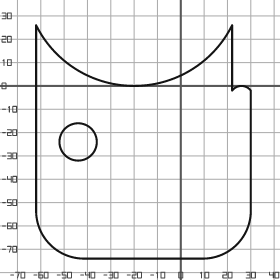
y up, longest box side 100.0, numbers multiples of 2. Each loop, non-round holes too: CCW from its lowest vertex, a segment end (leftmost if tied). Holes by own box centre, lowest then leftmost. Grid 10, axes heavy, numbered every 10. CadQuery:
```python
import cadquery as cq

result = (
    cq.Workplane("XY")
    .moveTo(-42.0, -74.0)
    .lineTo(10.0, -74.0)
    .threePointArc((24.0, -68.0), (30.0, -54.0))
    .lineTo(30.0, -2.0)
    .threePointArc((26.0, 0.0), (22.0, -2.0))
    .lineTo(22.0, 26.0)
    .threePointArc((-20.0, 0.0), (-62.0, 26.0))
    .lineTo(-62.0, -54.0)
    .threePointArc((-56.0, -68.0), (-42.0, -74.0))
    .close()
    .moveTo(-44.0, -24.0)
    .circle(8.0)
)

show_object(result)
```